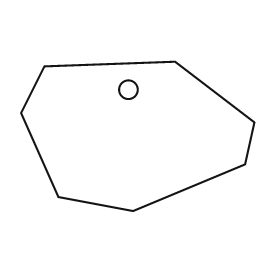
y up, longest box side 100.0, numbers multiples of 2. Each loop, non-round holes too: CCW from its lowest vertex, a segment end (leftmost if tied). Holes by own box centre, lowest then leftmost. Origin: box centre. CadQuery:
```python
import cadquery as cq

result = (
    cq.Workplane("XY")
    .moveTo(-2.0, -32.0)
    .lineTo(46.0, -12.0)
    .lineTo(50.0, 6.0)
    .lineTo(16.0, 32.0)
    .lineTo(-40.0, 30.0)
    .lineTo(-50.0, 10.0)
    .lineTo(-34.0, -26.0)
    .close()
    .moveTo(-4.0, 20.0)
    .circle(4.0)
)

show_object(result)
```